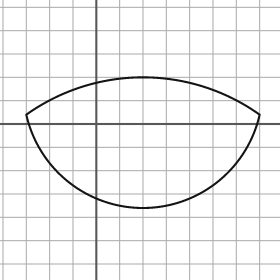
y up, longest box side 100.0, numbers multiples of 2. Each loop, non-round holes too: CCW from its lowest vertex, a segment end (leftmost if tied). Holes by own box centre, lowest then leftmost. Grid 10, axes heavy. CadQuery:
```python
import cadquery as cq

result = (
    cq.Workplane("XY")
    .moveTo(-30.0, 4.0)
    .threePointArc((20.0, -36.0), (70.0, 4.0))
    .threePointArc((20.0, 20.0), (-30.0, 4.0))
    .close()
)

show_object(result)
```